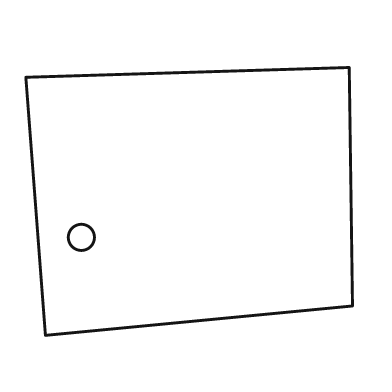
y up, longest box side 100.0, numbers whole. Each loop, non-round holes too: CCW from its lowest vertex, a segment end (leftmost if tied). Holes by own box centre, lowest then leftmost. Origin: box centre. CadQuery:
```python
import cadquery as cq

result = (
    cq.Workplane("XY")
    .moveTo(-44.0, -41.0)
    .lineTo(50.0, -32.0)
    .lineTo(49.0, 41.0)
    .lineTo(-50.0, 38.0)
    .close()
    .moveTo(-33.0, -11.0)
    .circle(4.0)
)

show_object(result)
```